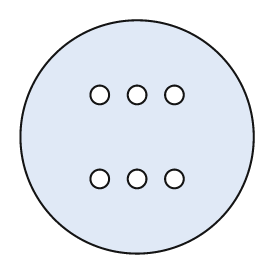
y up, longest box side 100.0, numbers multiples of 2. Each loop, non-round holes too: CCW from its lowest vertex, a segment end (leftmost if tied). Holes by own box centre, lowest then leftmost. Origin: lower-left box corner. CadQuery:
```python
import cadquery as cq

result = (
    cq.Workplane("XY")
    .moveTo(50.0, 50.0)
    .circle(50.0)
    .moveTo(34.0, 32.0)
    .circle(4.0)
    .moveTo(50.0, 32.0)
    .circle(4.0)
    .moveTo(66.0, 32.0)
    .circle(4.0)
    .moveTo(34.0, 68.0)
    .circle(4.0)
    .moveTo(50.0, 68.0)
    .circle(4.0)
    .moveTo(66.0, 68.0)
    .circle(4.0)
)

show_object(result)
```